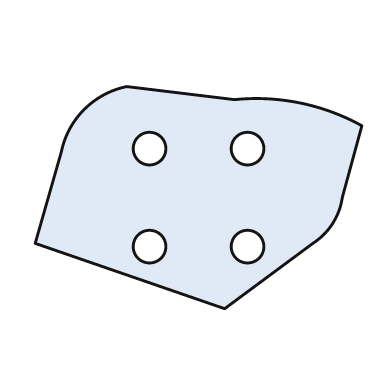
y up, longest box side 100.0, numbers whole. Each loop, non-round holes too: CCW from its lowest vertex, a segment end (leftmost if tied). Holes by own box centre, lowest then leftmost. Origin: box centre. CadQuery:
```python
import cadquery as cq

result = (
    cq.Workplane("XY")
    .moveTo(8.0, -34.0)
    .lineTo(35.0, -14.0)
    .threePointArc((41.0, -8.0), (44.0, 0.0))
    .lineTo(50.0, 22.0)
    .threePointArc((31.0, 29.0), (11.0, 30.0))
    .lineTo(-22.0, 34.0)
    .threePointArc((-35.0, 27.0), (-42.0, 14.0))
    .lineTo(-50.0, -14.0)
    .close()
    .moveTo(-15.0, -15.0)
    .circle(5.0)
    .moveTo(15.0, -15.0)
    .circle(5.0)
    .moveTo(-15.0, 15.0)
    .circle(5.0)
    .moveTo(15.0, 15.0)
    .circle(5.0)
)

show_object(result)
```